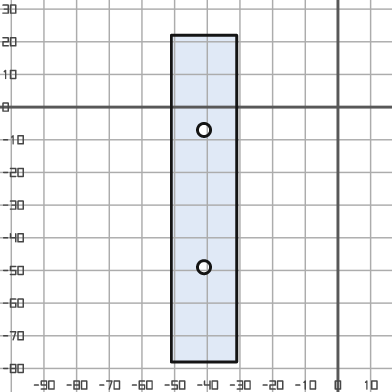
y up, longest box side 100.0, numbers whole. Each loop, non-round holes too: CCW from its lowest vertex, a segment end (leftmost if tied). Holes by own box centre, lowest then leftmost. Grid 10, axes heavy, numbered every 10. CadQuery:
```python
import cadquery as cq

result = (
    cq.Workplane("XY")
    .moveTo(-51.0, -78.0)
    .lineTo(-31.0, -78.0)
    .lineTo(-31.0, 22.0)
    .lineTo(-51.0, 22.0)
    .close()
    .moveTo(-41.0, -49.0)
    .circle(2.0)
    .moveTo(-41.0, -7.0)
    .circle(2.0)
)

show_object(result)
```